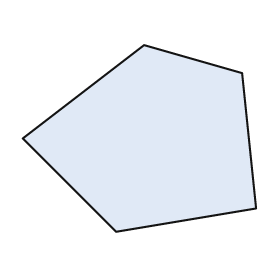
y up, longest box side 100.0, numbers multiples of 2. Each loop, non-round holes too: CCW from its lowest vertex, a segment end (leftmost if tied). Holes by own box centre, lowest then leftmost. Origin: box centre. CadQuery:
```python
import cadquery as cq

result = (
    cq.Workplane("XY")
    .moveTo(-10.0, -40.0)
    .lineTo(50.0, -30.0)
    .lineTo(44.0, 28.0)
    .lineTo(2.0, 40.0)
    .lineTo(-50.0, 0.0)
    .close()
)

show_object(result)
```